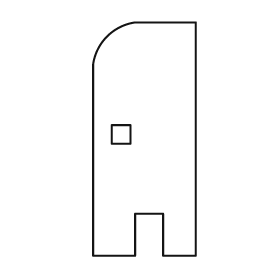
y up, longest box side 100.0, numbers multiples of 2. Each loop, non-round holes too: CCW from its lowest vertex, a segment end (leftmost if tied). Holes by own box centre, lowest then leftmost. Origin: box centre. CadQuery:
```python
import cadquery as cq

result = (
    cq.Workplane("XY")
    .moveTo(-22.0, -50.0)
    .lineTo(-4.0, -50.0)
    .lineTo(-4.0, -32.0)
    .lineTo(8.0, -32.0)
    .lineTo(8.0, -50.0)
    .lineTo(22.0, -50.0)
    .lineTo(22.0, 50.0)
    .lineTo(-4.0, 50.0)
    .threePointArc((-16.0, 44.0), (-22.0, 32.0))
    .close()
    .moveTo(-14.0, -2.0)
    .lineTo(-6.0, -2.0)
    .lineTo(-6.0, 6.0)
    .lineTo(-14.0, 6.0)
    .close()
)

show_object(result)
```